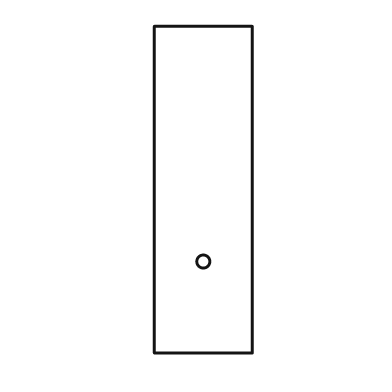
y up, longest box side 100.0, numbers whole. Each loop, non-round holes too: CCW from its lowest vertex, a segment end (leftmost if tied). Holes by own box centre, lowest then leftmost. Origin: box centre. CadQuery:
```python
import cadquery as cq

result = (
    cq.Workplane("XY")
    .moveTo(-15.0, -50.0)
    .lineTo(15.0, -50.0)
    .lineTo(15.0, 50.0)
    .lineTo(-15.0, 50.0)
    .close()
    .moveTo(0.0, -22.0)
    .circle(2.0)
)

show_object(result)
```